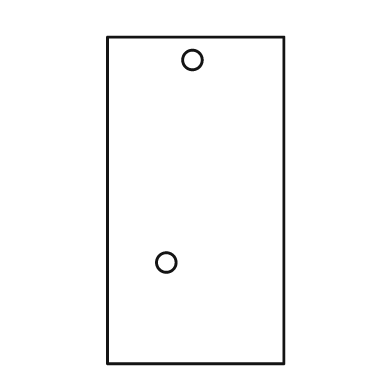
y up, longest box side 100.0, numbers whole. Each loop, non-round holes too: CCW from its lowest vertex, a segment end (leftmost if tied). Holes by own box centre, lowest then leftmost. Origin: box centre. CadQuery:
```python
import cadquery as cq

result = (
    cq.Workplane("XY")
    .moveTo(-27.0, -50.0)
    .lineTo(27.0, -50.0)
    .lineTo(27.0, 50.0)
    .lineTo(-27.0, 50.0)
    .close()
    .moveTo(-9.0, -19.0)
    .circle(3.0)
    .moveTo(-1.0, 43.0)
    .circle(3.0)
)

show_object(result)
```